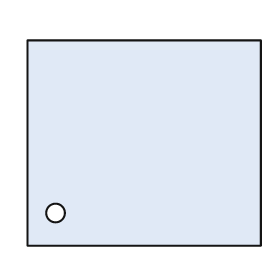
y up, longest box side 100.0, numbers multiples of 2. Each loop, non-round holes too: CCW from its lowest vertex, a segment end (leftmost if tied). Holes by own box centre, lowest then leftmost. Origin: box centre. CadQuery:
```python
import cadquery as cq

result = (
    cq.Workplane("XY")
    .moveTo(-50.0, -44.0)
    .lineTo(50.0, -44.0)
    .lineTo(50.0, 44.0)
    .lineTo(-50.0, 44.0)
    .close()
    .moveTo(-38.0, -30.0)
    .circle(4.0)
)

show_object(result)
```